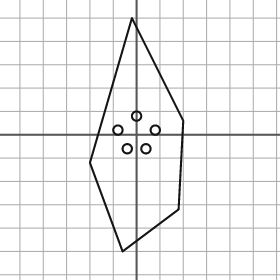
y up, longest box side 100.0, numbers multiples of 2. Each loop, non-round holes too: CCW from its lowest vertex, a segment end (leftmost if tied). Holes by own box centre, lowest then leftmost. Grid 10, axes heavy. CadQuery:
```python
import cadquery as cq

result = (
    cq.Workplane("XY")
    .moveTo(-6.0, -50.0)
    .lineTo(18.0, -32.0)
    .lineTo(20.0, 6.0)
    .lineTo(-2.0, 50.0)
    .lineTo(-20.0, -12.0)
    .close()
    .moveTo(-4.0, -6.0)
    .circle(2.0)
    .moveTo(4.0, -6.0)
    .circle(2.0)
    .moveTo(-8.0, 2.0)
    .circle(2.0)
    .moveTo(8.0, 2.0)
    .circle(2.0)
    .moveTo(0.0, 8.0)
    .circle(2.0)
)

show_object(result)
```